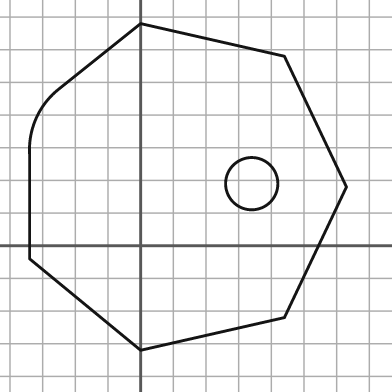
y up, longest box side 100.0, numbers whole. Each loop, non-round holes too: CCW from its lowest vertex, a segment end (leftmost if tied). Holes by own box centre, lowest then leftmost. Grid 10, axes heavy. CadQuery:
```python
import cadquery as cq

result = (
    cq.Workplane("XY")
    .moveTo(0.0, -32.0)
    .lineTo(44.0, -22.0)
    .lineTo(63.0, 18.0)
    .lineTo(44.0, 58.0)
    .lineTo(0.0, 68.0)
    .lineTo(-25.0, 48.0)
    .threePointArc((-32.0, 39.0), (-34.0, 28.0))
    .lineTo(-34.0, -4.0)
    .close()
    .moveTo(34.0, 19.0)
    .circle(8.0)
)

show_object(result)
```